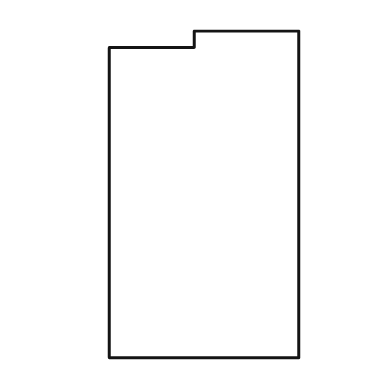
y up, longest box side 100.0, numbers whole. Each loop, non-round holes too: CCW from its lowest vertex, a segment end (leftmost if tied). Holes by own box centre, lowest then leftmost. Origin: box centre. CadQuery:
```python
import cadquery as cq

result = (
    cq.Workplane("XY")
    .moveTo(-29.0, -50.0)
    .lineTo(29.0, -50.0)
    .lineTo(29.0, 50.0)
    .lineTo(-3.0, 50.0)
    .lineTo(-3.0, 45.0)
    .lineTo(-29.0, 45.0)
    .close()
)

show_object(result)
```